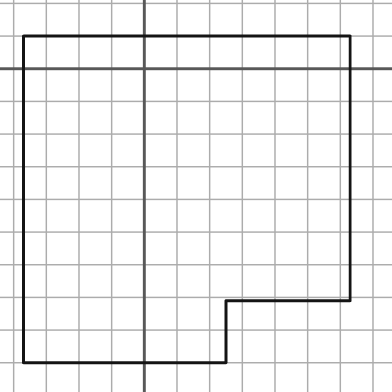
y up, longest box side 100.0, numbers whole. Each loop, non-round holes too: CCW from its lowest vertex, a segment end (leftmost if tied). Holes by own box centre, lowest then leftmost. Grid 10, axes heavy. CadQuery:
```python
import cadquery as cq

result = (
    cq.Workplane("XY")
    .moveTo(-37.0, -90.0)
    .lineTo(25.0, -90.0)
    .lineTo(25.0, -71.0)
    .lineTo(63.0, -71.0)
    .lineTo(63.0, 10.0)
    .lineTo(-37.0, 10.0)
    .close()
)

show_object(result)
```